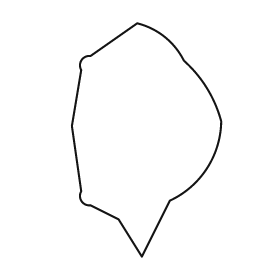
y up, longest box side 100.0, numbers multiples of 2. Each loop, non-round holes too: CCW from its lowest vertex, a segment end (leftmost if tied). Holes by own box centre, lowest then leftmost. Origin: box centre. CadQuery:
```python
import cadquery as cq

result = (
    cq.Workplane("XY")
    .moveTo(-2.0, -50.0)
    .lineTo(10.0, -26.0)
    .threePointArc((26.0, -12.0), (32.0, 8.0))
    .threePointArc((26.0, 22.0), (16.0, 34.0))
    .threePointArc((8.0, 44.0), (-4.0, 50.0))
    .lineTo(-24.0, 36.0)
    .threePointArc((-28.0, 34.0), (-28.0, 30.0))
    .lineTo(-32.0, 6.0)
    .lineTo(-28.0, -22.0)
    .threePointArc((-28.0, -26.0), (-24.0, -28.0))
    .lineTo(-12.0, -34.0)
    .close()
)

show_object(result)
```